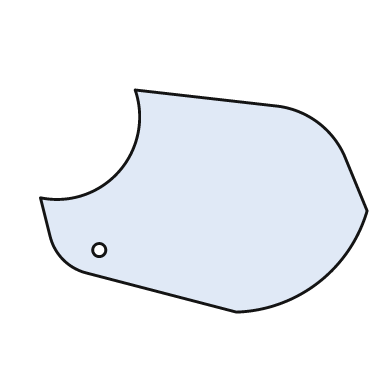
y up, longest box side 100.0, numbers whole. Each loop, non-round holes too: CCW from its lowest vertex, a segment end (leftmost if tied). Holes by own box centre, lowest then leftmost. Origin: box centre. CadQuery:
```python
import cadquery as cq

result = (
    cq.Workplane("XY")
    .moveTo(10.0, -34.0)
    .threePointArc((35.0, -25.0), (50.0, -3.0))
    .lineTo(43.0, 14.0)
    .threePointArc((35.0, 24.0), (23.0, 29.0))
    .lineTo(-21.0, 34.0)
    .threePointArc((-26.0, 9.0), (-50.0, 1.0))
    .lineTo(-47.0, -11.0)
    .threePointArc((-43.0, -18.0), (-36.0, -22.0))
    .close()
    .moveTo(-32.0, -15.0)
    .circle(2.0)
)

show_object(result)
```